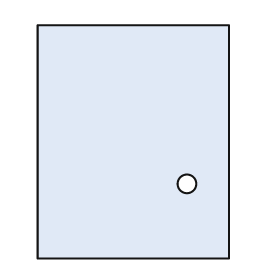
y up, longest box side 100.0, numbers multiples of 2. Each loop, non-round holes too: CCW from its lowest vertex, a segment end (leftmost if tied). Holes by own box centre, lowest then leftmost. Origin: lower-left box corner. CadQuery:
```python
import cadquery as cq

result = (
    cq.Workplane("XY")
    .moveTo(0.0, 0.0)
    .lineTo(82.0, 0.0)
    .lineTo(82.0, 100.0)
    .lineTo(0.0, 100.0)
    .close()
    .moveTo(64.0, 32.0)
    .circle(4.0)
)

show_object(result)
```